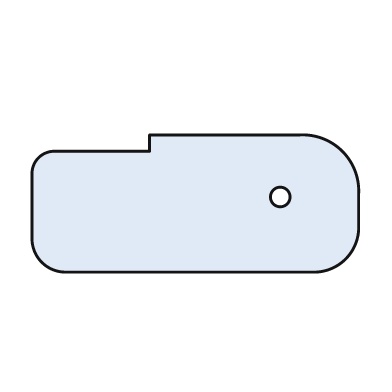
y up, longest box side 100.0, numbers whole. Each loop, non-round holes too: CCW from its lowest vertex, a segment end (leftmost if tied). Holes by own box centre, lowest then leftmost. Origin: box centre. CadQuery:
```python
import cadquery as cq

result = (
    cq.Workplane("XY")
    .moveTo(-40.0, -21.0)
    .lineTo(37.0, -21.0)
    .threePointArc((46.0, -17.0), (50.0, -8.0))
    .lineTo(50.0, 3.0)
    .threePointArc((45.0, 16.0), (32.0, 21.0))
    .lineTo(-14.0, 21.0)
    .lineTo(-14.0, 16.0)
    .lineTo(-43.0, 16.0)
    .threePointArc((-48.0, 14.0), (-50.0, 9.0))
    .lineTo(-50.0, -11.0)
    .threePointArc((-47.0, -18.0), (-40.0, -21.0))
    .close()
    .moveTo(26.0, 2.0)
    .circle(3.0)
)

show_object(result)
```